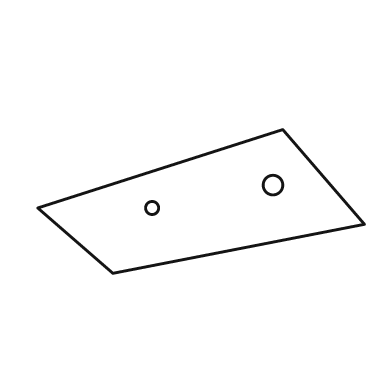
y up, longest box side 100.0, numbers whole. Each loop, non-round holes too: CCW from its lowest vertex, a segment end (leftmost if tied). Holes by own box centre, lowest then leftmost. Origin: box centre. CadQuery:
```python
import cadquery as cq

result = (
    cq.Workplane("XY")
    .moveTo(-27.0, -22.0)
    .lineTo(50.0, -7.0)
    .lineTo(25.0, 22.0)
    .lineTo(-50.0, -2.0)
    .close()
    .moveTo(-15.0, -2.0)
    .circle(2.0)
    .moveTo(22.0, 5.0)
    .circle(3.0)
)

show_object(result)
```